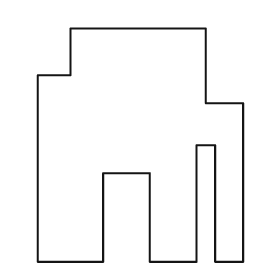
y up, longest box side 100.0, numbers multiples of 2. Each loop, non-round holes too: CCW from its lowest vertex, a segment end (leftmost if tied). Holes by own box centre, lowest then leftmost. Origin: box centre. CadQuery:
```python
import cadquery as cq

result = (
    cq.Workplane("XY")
    .moveTo(-44.0, -50.0)
    .lineTo(-16.0, -50.0)
    .lineTo(-16.0, -12.0)
    .lineTo(4.0, -12.0)
    .lineTo(4.0, -50.0)
    .lineTo(24.0, -50.0)
    .lineTo(24.0, 0.0)
    .lineTo(32.0, 0.0)
    .lineTo(32.0, -50.0)
    .lineTo(44.0, -50.0)
    .lineTo(44.0, 18.0)
    .lineTo(28.0, 18.0)
    .lineTo(28.0, 50.0)
    .lineTo(-30.0, 50.0)
    .lineTo(-30.0, 30.0)
    .lineTo(-44.0, 30.0)
    .close()
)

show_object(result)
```